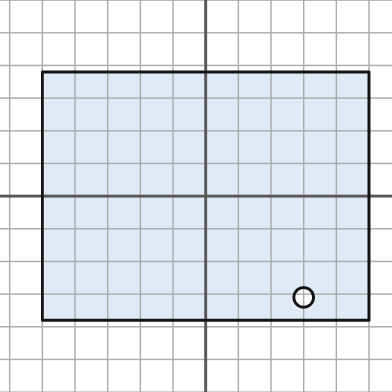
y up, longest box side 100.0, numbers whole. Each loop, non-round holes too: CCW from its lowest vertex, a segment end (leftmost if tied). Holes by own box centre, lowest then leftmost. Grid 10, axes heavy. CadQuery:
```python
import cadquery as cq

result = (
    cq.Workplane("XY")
    .moveTo(-50.0, -38.0)
    .lineTo(50.0, -38.0)
    .lineTo(50.0, 38.0)
    .lineTo(-50.0, 38.0)
    .close()
    .moveTo(30.0, -31.0)
    .circle(3.0)
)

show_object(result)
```